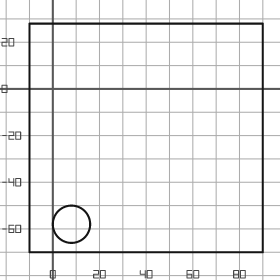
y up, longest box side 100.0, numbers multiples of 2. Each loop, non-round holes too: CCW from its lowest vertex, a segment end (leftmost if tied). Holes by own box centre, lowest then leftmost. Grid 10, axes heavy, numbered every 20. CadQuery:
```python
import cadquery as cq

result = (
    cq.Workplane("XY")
    .moveTo(-10.0, -70.0)
    .lineTo(90.0, -70.0)
    .lineTo(90.0, 28.0)
    .lineTo(-10.0, 28.0)
    .close()
    .moveTo(8.0, -58.0)
    .circle(8.0)
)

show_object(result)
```